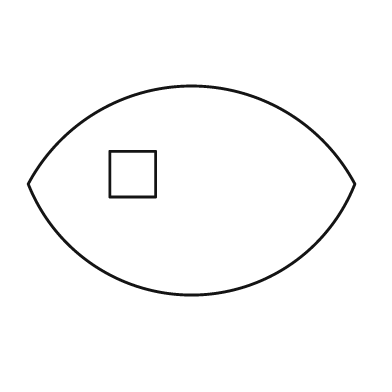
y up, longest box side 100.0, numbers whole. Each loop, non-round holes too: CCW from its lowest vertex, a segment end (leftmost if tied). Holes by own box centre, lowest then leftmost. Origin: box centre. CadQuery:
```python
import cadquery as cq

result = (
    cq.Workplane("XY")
    .moveTo(-50.0, 2.0)
    .threePointArc((0.0, -32.0), (50.0, 2.0))
    .threePointArc((0.0, 32.0), (-50.0, 2.0))
    .close()
    .moveTo(-25.0, -2.0)
    .lineTo(-11.0, -2.0)
    .lineTo(-11.0, 12.0)
    .lineTo(-25.0, 12.0)
    .close()
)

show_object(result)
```